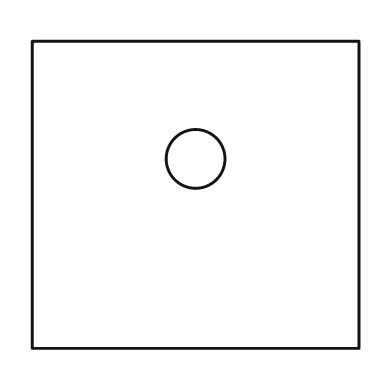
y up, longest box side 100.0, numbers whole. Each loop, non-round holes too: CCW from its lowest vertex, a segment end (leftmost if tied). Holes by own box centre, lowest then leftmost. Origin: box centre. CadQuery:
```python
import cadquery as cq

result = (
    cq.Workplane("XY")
    .moveTo(-50.0, -47.0)
    .lineTo(50.0, -47.0)
    .lineTo(50.0, 47.0)
    .lineTo(-50.0, 47.0)
    .close()
    .moveTo(0.0, 11.0)
    .circle(9.0)
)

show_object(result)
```